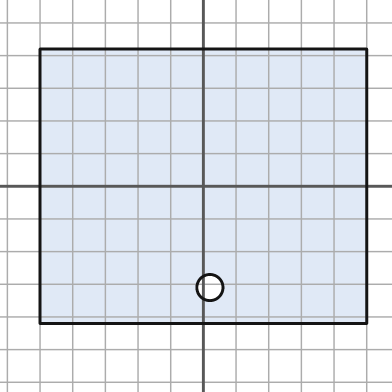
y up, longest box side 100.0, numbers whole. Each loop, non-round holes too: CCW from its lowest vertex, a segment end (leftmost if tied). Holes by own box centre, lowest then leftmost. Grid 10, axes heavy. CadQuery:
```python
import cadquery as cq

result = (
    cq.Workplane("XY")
    .moveTo(-50.0, -42.0)
    .lineTo(50.0, -42.0)
    .lineTo(50.0, 42.0)
    .lineTo(-50.0, 42.0)
    .close()
    .moveTo(2.0, -31.0)
    .circle(4.0)
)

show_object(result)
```